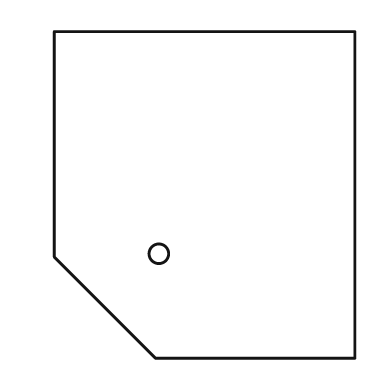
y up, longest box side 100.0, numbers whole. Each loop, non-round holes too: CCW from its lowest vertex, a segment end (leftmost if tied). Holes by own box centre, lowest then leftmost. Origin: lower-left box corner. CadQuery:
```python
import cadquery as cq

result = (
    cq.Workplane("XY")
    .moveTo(31.0, 0.0)
    .lineTo(92.0, 0.0)
    .lineTo(92.0, 100.0)
    .lineTo(0.0, 100.0)
    .lineTo(0.0, 31.0)
    .close()
    .moveTo(32.0, 32.0)
    .circle(3.0)
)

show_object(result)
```